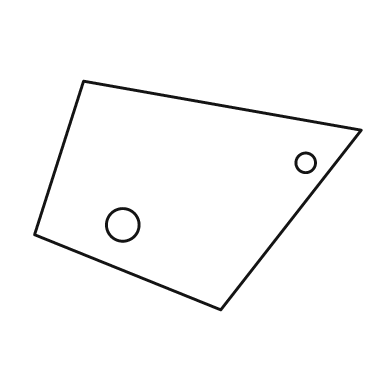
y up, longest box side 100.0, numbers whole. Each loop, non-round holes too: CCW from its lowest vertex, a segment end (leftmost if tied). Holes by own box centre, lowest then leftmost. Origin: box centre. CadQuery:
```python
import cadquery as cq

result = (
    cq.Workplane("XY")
    .moveTo(7.0, -35.0)
    .lineTo(50.0, 20.0)
    .lineTo(-35.0, 35.0)
    .lineTo(-50.0, -12.0)
    .close()
    .moveTo(-23.0, -9.0)
    .circle(5.0)
    .moveTo(33.0, 10.0)
    .circle(3.0)
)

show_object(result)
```